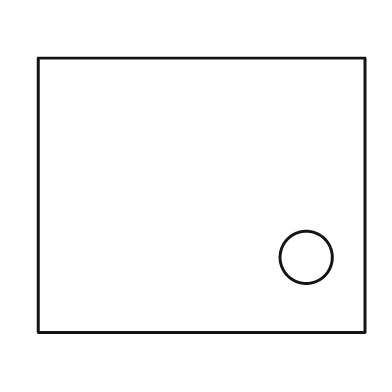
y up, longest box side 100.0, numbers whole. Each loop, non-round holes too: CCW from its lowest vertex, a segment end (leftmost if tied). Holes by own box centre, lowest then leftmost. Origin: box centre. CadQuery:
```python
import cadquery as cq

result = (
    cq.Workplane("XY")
    .moveTo(-50.0, -42.0)
    .lineTo(50.0, -42.0)
    .lineTo(50.0, 42.0)
    .lineTo(-50.0, 42.0)
    .close()
    .moveTo(32.0, -19.0)
    .circle(8.0)
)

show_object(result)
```